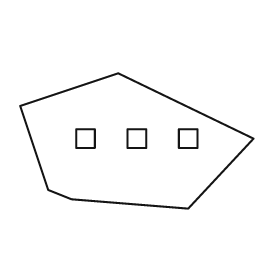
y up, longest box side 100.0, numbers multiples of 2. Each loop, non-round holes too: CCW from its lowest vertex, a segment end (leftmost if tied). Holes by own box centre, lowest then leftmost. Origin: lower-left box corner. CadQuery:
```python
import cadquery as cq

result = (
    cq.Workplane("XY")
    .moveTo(72.0, 0.0)
    .lineTo(100.0, 30.0)
    .lineTo(42.0, 58.0)
    .lineTo(0.0, 44.0)
    .lineTo(12.0, 8.0)
    .lineTo(22.0, 4.0)
    .close()
    .moveTo(24.0, 26.0)
    .lineTo(32.0, 26.0)
    .lineTo(32.0, 34.0)
    .lineTo(24.0, 34.0)
    .close()
    .moveTo(46.0, 26.0)
    .lineTo(54.0, 26.0)
    .lineTo(54.0, 34.0)
    .lineTo(46.0, 34.0)
    .close()
    .moveTo(68.0, 26.0)
    .lineTo(76.0, 26.0)
    .lineTo(76.0, 34.0)
    .lineTo(68.0, 34.0)
    .close()
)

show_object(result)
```